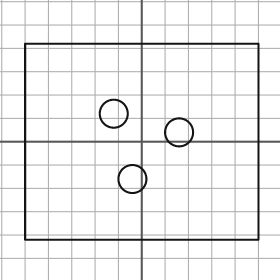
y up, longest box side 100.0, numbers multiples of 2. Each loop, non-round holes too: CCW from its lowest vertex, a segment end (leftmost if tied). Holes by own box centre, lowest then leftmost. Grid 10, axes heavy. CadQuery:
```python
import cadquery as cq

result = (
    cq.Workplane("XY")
    .moveTo(-50.0, -42.0)
    .lineTo(50.0, -42.0)
    .lineTo(50.0, 42.0)
    .lineTo(-50.0, 42.0)
    .close()
    .moveTo(-4.0, -16.0)
    .circle(6.0)
    .moveTo(16.0, 4.0)
    .circle(6.0)
    .moveTo(-12.0, 12.0)
    .circle(6.0)
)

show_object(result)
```